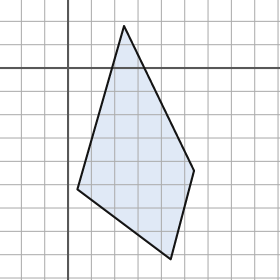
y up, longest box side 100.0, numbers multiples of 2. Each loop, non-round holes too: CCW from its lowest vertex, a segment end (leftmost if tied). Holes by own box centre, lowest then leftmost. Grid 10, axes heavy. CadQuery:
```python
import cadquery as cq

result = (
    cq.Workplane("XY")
    .moveTo(44.0, -82.0)
    .lineTo(54.0, -44.0)
    .lineTo(24.0, 18.0)
    .lineTo(4.0, -52.0)
    .close()
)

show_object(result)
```